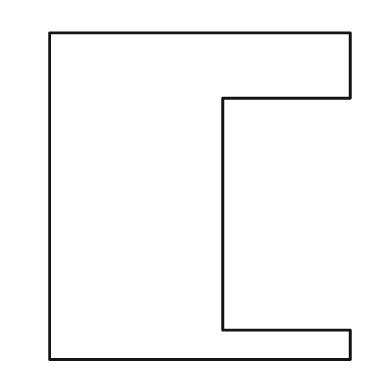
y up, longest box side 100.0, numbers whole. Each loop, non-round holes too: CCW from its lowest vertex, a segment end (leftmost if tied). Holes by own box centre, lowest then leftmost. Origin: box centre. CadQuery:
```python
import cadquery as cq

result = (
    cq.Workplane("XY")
    .moveTo(-46.0, -50.0)
    .lineTo(46.0, -50.0)
    .lineTo(46.0, -41.0)
    .lineTo(7.0, -41.0)
    .lineTo(7.0, 30.0)
    .lineTo(46.0, 30.0)
    .lineTo(46.0, 50.0)
    .lineTo(-46.0, 50.0)
    .close()
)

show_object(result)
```